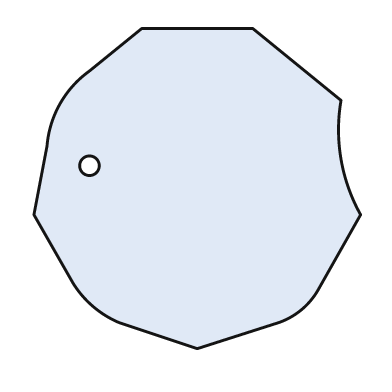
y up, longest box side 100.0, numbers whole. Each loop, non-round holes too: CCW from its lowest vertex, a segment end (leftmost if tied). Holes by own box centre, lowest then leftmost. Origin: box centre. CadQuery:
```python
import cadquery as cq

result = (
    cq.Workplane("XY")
    .moveTo(0.0, -49.0)
    .lineTo(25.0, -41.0)
    .threePointArc((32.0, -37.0), (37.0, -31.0))
    .lineTo(50.0, -8.0)
    .threePointArc((44.0, 9.0), (44.0, 27.0))
    .lineTo(17.0, 49.0)
    .lineTo(-17.0, 49.0)
    .lineTo(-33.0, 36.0)
    .threePointArc((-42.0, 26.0), (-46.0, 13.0))
    .lineTo(-50.0, -8.0)
    .lineTo(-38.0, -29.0)
    .threePointArc((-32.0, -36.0), (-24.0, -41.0))
    .close()
    .moveTo(-33.0, 7.0)
    .circle(3.0)
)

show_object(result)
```